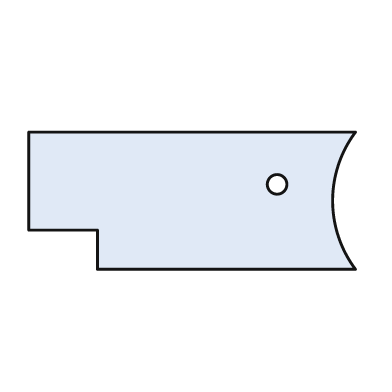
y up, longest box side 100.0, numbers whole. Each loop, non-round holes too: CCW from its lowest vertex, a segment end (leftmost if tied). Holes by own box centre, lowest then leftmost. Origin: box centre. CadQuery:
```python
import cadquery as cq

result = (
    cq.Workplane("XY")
    .moveTo(-29.0, -21.0)
    .lineTo(50.0, -21.0)
    .threePointArc((43.0, 0.0), (50.0, 21.0))
    .lineTo(-50.0, 21.0)
    .lineTo(-50.0, -9.0)
    .lineTo(-29.0, -9.0)
    .close()
    .moveTo(26.0, 5.0)
    .circle(3.0)
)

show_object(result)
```